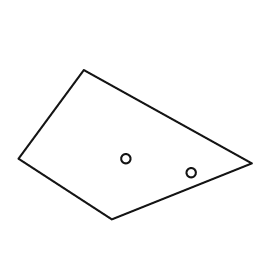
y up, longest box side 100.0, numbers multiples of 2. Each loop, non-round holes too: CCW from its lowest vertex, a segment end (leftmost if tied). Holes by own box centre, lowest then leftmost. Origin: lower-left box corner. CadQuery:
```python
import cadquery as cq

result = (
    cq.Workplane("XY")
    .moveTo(40.0, 0.0)
    .lineTo(100.0, 24.0)
    .lineTo(28.0, 64.0)
    .lineTo(0.0, 26.0)
    .close()
    .moveTo(74.0, 20.0)
    .circle(2.0)
    .moveTo(46.0, 26.0)
    .circle(2.0)
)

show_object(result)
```